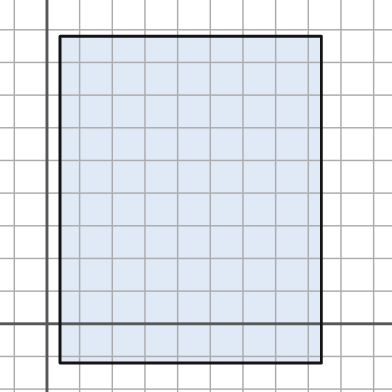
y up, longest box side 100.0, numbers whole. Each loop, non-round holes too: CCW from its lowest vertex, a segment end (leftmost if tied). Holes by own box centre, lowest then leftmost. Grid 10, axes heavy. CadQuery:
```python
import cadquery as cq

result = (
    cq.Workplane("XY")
    .moveTo(4.0, -12.0)
    .lineTo(84.0, -12.0)
    .lineTo(84.0, 88.0)
    .lineTo(4.0, 88.0)
    .close()
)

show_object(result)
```